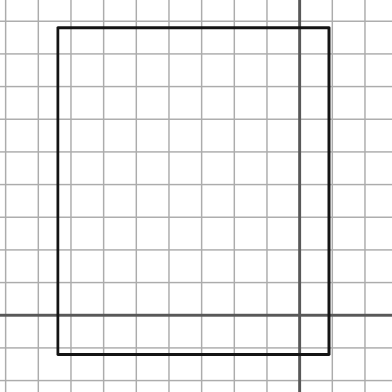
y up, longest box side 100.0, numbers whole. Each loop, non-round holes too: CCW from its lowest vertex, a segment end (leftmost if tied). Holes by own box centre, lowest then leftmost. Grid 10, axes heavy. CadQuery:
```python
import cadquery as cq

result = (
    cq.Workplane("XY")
    .moveTo(-74.0, -12.0)
    .lineTo(9.0, -12.0)
    .lineTo(9.0, 88.0)
    .lineTo(-74.0, 88.0)
    .close()
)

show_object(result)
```